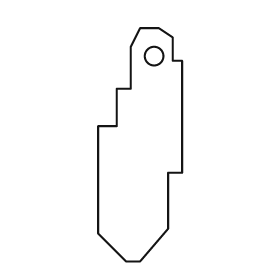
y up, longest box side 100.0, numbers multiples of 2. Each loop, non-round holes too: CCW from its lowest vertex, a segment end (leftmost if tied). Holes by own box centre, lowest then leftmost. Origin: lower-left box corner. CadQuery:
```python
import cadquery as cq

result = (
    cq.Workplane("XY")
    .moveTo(12.0, 0.0)
    .lineTo(18.0, 0.0)
    .lineTo(30.0, 14.0)
    .lineTo(30.0, 38.0)
    .lineTo(36.0, 38.0)
    .lineTo(36.0, 86.0)
    .lineTo(32.0, 86.0)
    .lineTo(32.0, 96.0)
    .lineTo(26.0, 100.0)
    .lineTo(18.0, 100.0)
    .lineTo(14.0, 92.0)
    .lineTo(14.0, 74.0)
    .lineTo(8.0, 74.0)
    .lineTo(8.0, 58.0)
    .lineTo(0.0, 58.0)
    .lineTo(0.0, 12.0)
    .close()
    .moveTo(24.0, 88.0)
    .circle(4.0)
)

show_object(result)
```